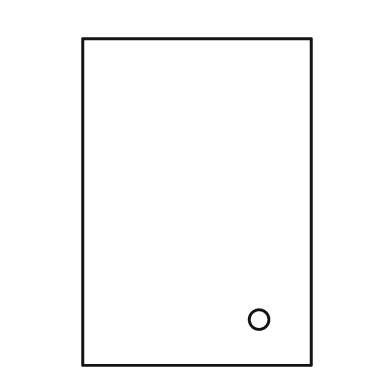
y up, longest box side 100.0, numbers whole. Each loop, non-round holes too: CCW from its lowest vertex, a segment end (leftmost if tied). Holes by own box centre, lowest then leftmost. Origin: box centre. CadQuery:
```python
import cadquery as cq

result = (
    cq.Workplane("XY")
    .moveTo(-35.0, -50.0)
    .lineTo(35.0, -50.0)
    .lineTo(35.0, 50.0)
    .lineTo(-35.0, 50.0)
    .close()
    .moveTo(19.0, -36.0)
    .circle(3.0)
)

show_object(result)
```